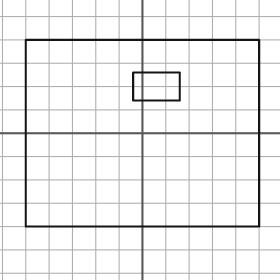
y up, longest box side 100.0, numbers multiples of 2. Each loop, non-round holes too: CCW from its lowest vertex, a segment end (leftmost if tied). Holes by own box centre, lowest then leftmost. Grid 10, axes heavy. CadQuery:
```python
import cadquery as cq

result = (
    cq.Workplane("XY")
    .moveTo(-50.0, -40.0)
    .lineTo(50.0, -40.0)
    .lineTo(50.0, 40.0)
    .lineTo(-50.0, 40.0)
    .close()
    .moveTo(-4.0, 14.0)
    .lineTo(16.0, 14.0)
    .lineTo(16.0, 26.0)
    .lineTo(-4.0, 26.0)
    .close()
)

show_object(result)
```